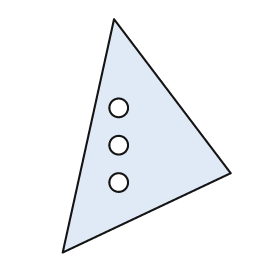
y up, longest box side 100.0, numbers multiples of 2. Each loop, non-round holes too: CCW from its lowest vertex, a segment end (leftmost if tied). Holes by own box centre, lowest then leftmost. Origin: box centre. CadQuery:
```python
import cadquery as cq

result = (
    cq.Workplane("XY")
    .moveTo(-36.0, -50.0)
    .lineTo(36.0, -16.0)
    .lineTo(-14.0, 50.0)
    .close()
    .moveTo(-12.0, -20.0)
    .circle(4.0)
    .moveTo(-12.0, -4.0)
    .circle(4.0)
    .moveTo(-12.0, 12.0)
    .circle(4.0)
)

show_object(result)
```